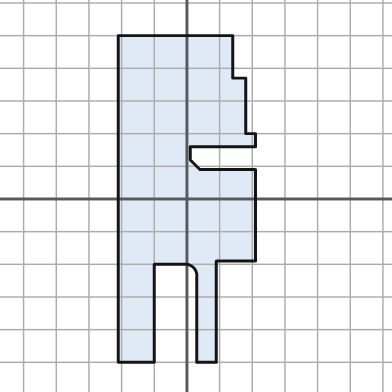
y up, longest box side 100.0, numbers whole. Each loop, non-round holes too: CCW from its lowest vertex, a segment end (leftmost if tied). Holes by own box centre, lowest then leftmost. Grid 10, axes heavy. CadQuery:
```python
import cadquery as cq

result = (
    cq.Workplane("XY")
    .moveTo(-21.0, -50.0)
    .lineTo(-10.0, -50.0)
    .lineTo(-10.0, -20.0)
    .lineTo(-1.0, -20.0)
    .threePointArc((2.0, -21.0), (3.0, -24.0))
    .lineTo(3.0, -50.0)
    .lineTo(9.0, -50.0)
    .lineTo(9.0, -19.0)
    .lineTo(21.0, -19.0)
    .lineTo(21.0, 9.0)
    .lineTo(4.0, 9.0)
    .lineTo(1.0, 12.0)
    .lineTo(1.0, 16.0)
    .lineTo(21.0, 16.0)
    .lineTo(21.0, 20.0)
    .lineTo(18.0, 20.0)
    .lineTo(18.0, 37.0)
    .lineTo(14.0, 37.0)
    .lineTo(14.0, 50.0)
    .lineTo(-21.0, 50.0)
    .close()
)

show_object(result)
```